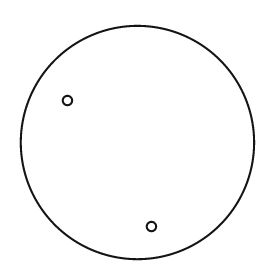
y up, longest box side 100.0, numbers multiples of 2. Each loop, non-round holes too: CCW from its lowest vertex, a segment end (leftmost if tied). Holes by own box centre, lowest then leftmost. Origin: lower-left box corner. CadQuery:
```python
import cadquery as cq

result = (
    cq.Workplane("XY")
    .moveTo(50.0, 50.0)
    .circle(50.0)
    .moveTo(56.0, 14.0)
    .circle(2.0)
    .moveTo(20.0, 68.0)
    .circle(2.0)
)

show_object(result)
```